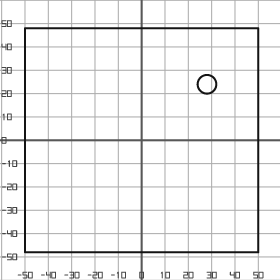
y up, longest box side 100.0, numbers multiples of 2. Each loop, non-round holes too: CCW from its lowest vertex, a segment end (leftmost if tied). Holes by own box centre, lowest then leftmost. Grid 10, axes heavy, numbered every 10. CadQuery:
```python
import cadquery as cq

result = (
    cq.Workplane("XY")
    .moveTo(-50.0, -48.0)
    .lineTo(50.0, -48.0)
    .lineTo(50.0, 48.0)
    .lineTo(-50.0, 48.0)
    .close()
    .moveTo(28.0, 24.0)
    .circle(4.0)
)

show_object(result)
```